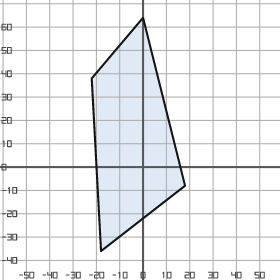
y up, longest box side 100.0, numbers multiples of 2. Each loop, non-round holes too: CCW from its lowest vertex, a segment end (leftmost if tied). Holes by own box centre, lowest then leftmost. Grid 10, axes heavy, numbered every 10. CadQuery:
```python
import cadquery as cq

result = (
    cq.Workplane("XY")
    .moveTo(-18.0, -36.0)
    .lineTo(18.0, -8.0)
    .lineTo(0.0, 64.0)
    .lineTo(-22.0, 38.0)
    .close()
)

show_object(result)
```